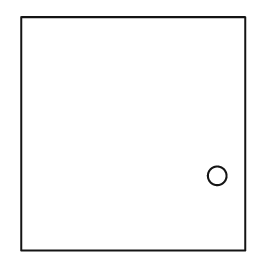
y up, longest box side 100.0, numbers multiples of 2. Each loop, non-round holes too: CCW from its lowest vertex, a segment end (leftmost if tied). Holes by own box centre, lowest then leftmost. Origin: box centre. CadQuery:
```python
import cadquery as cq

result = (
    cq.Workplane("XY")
    .moveTo(-48.0, -50.0)
    .lineTo(48.0, -50.0)
    .lineTo(48.0, 50.0)
    .lineTo(-48.0, 50.0)
    .close()
    .moveTo(36.0, -18.0)
    .circle(4.0)
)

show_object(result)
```